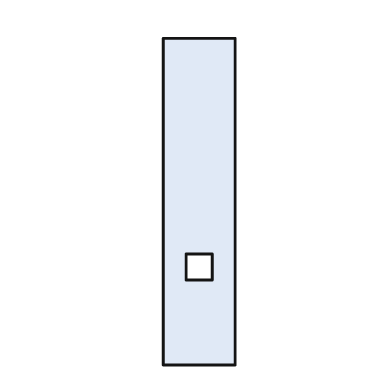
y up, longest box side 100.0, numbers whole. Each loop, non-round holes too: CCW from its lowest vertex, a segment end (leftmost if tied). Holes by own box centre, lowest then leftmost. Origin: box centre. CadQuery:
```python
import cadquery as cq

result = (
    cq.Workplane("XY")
    .moveTo(-11.0, -50.0)
    .lineTo(11.0, -50.0)
    .lineTo(11.0, 50.0)
    .lineTo(-11.0, 50.0)
    .close()
    .moveTo(-4.0, -24.0)
    .lineTo(4.0, -24.0)
    .lineTo(4.0, -16.0)
    .lineTo(-4.0, -16.0)
    .close()
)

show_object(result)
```